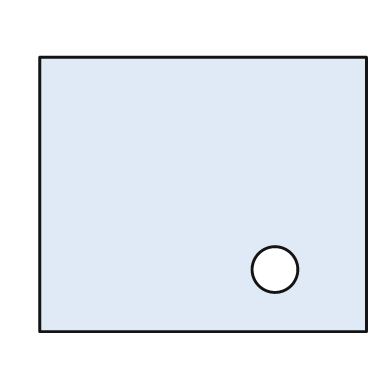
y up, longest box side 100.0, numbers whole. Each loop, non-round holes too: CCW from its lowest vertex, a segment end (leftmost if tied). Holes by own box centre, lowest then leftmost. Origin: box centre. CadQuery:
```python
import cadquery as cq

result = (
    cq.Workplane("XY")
    .moveTo(-50.0, -42.0)
    .lineTo(50.0, -42.0)
    .lineTo(50.0, 42.0)
    .lineTo(-50.0, 42.0)
    .close()
    .moveTo(22.0, -23.0)
    .circle(7.0)
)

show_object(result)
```